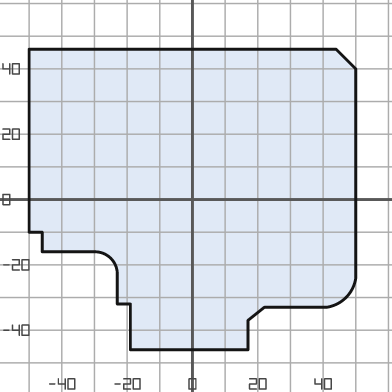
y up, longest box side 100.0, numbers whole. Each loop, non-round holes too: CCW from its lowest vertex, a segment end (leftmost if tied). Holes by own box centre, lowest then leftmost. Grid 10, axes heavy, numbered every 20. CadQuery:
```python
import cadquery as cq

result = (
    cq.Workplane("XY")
    .moveTo(-19.0, -46.0)
    .lineTo(17.0, -46.0)
    .lineTo(17.0, -37.0)
    .lineTo(22.0, -33.0)
    .lineTo(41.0, -33.0)
    .threePointArc((47.0, -30.0), (50.0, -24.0))
    .lineTo(50.0, 40.0)
    .lineTo(44.0, 46.0)
    .lineTo(-50.0, 46.0)
    .lineTo(-50.0, -10.0)
    .lineTo(-46.0, -10.0)
    .lineTo(-46.0, -16.0)
    .lineTo(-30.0, -16.0)
    .threePointArc((-25.0, -18.0), (-23.0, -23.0))
    .lineTo(-23.0, -32.0)
    .lineTo(-19.0, -32.0)
    .close()
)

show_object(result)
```